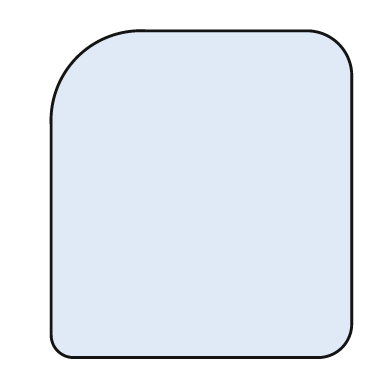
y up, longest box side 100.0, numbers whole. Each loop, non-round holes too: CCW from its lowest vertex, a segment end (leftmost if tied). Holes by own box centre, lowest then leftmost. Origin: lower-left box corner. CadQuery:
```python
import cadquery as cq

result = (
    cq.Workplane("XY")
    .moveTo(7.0, 0.0)
    .lineTo(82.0, 0.0)
    .threePointArc((89.0, 3.0), (92.0, 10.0))
    .lineTo(92.0, 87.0)
    .threePointArc((88.0, 96.0), (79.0, 100.0))
    .lineTo(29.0, 100.0)
    .threePointArc((8.0, 92.0), (0.0, 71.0))
    .lineTo(0.0, 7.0)
    .threePointArc((2.0, 2.0), (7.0, 0.0))
    .close()
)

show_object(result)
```